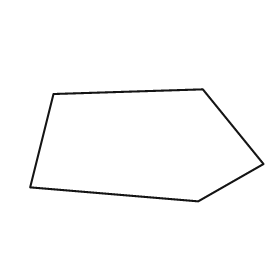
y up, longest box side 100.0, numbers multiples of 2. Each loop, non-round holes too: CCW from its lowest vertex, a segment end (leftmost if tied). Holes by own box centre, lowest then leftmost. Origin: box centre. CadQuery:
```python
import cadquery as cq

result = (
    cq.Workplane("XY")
    .moveTo(22.0, -24.0)
    .lineTo(50.0, -8.0)
    .lineTo(24.0, 24.0)
    .lineTo(-40.0, 22.0)
    .lineTo(-50.0, -18.0)
    .close()
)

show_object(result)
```